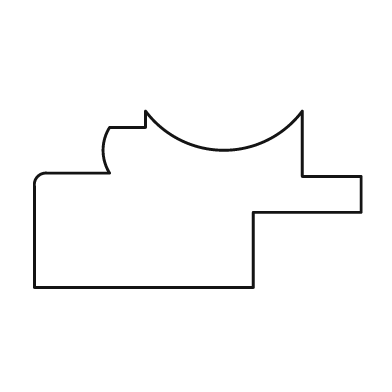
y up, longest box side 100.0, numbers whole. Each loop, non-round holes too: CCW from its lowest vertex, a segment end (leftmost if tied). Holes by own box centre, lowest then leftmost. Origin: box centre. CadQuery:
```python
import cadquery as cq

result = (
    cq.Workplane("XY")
    .moveTo(-50.0, -27.0)
    .lineTo(17.0, -27.0)
    .lineTo(17.0, -4.0)
    .lineTo(50.0, -4.0)
    .lineTo(50.0, 7.0)
    .lineTo(32.0, 7.0)
    .lineTo(32.0, 27.0)
    .threePointArc((8.0, 15.0), (-16.0, 27.0))
    .lineTo(-16.0, 22.0)
    .lineTo(-27.0, 22.0)
    .threePointArc((-29.0, 15.0), (-27.0, 8.0))
    .lineTo(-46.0, 8.0)
    .threePointArc((-49.0, 7.0), (-50.0, 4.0))
    .close()
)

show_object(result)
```